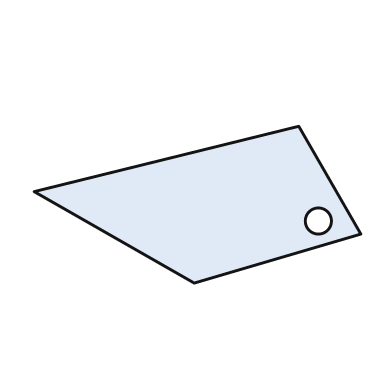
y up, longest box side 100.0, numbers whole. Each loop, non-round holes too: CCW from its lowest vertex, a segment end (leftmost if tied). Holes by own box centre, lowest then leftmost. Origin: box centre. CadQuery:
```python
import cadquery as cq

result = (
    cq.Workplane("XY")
    .moveTo(-1.0, -24.0)
    .lineTo(50.0, -9.0)
    .lineTo(31.0, 24.0)
    .lineTo(-50.0, 4.0)
    .close()
    .moveTo(37.0, -5.0)
    .circle(4.0)
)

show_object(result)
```